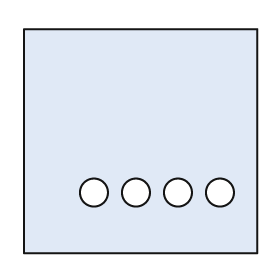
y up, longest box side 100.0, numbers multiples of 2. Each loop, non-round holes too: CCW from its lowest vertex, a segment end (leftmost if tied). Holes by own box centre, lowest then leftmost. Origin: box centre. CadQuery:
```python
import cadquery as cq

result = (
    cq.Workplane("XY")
    .moveTo(-50.0, -48.0)
    .lineTo(50.0, -48.0)
    .lineTo(50.0, 48.0)
    .lineTo(-50.0, 48.0)
    .close()
    .moveTo(-20.0, -22.0)
    .circle(6.0)
    .moveTo(-2.0, -22.0)
    .circle(6.0)
    .moveTo(16.0, -22.0)
    .circle(6.0)
    .moveTo(34.0, -22.0)
    .circle(6.0)
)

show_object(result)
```